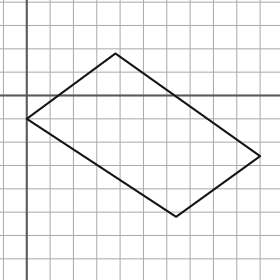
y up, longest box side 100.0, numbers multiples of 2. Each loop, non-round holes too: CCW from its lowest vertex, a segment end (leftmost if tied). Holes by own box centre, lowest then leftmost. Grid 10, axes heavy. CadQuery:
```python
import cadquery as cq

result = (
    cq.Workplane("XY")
    .moveTo(64.0, -52.0)
    .lineTo(100.0, -26.0)
    .lineTo(38.0, 18.0)
    .lineTo(0.0, -10.0)
    .close()
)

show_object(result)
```